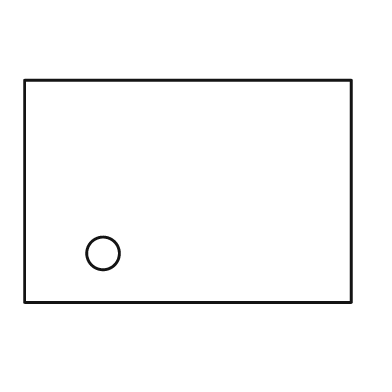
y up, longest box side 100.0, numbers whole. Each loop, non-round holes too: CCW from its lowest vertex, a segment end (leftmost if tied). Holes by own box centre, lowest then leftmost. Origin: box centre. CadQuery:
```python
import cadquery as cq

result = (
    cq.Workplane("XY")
    .moveTo(-50.0, -34.0)
    .lineTo(50.0, -34.0)
    .lineTo(50.0, 34.0)
    .lineTo(-50.0, 34.0)
    .close()
    .moveTo(-26.0, -19.0)
    .circle(5.0)
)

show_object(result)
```